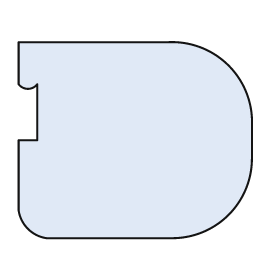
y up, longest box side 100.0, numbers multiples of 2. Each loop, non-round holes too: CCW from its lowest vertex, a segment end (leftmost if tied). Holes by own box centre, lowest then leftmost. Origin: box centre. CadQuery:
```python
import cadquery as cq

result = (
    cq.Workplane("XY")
    .moveTo(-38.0, -42.0)
    .lineTo(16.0, -42.0)
    .threePointArc((40.0, -32.0), (50.0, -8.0))
    .lineTo(50.0, 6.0)
    .threePointArc((40.0, 32.0), (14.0, 42.0))
    .lineTo(-50.0, 42.0)
    .lineTo(-50.0, 24.0)
    .threePointArc((-46.0, 22.0), (-42.0, 24.0))
    .lineTo(-42.0, 0.0)
    .lineTo(-50.0, 0.0)
    .lineTo(-50.0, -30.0)
    .threePointArc((-46.0, -38.0), (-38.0, -42.0))
    .close()
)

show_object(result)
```